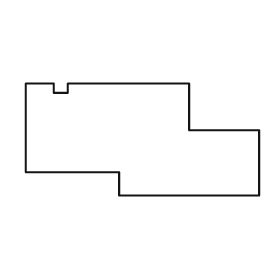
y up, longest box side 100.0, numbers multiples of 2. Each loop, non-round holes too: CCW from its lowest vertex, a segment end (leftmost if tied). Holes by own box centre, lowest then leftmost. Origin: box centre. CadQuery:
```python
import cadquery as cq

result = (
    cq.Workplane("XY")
    .moveTo(-10.0, -24.0)
    .lineTo(50.0, -24.0)
    .lineTo(50.0, 4.0)
    .lineTo(20.0, 4.0)
    .lineTo(20.0, 24.0)
    .lineTo(-32.0, 24.0)
    .lineTo(-32.0, 20.0)
    .lineTo(-38.0, 20.0)
    .lineTo(-38.0, 24.0)
    .lineTo(-50.0, 24.0)
    .lineTo(-50.0, -14.0)
    .lineTo(-10.0, -14.0)
    .close()
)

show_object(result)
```